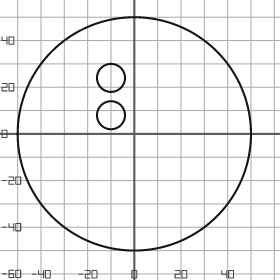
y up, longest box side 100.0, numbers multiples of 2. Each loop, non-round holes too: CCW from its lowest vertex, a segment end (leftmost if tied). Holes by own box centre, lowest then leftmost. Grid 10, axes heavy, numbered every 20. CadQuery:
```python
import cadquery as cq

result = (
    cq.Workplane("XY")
    .moveTo(0.0, 0.0)
    .circle(50.0)
    .moveTo(-10.0, 8.0)
    .circle(6.0)
    .moveTo(-10.0, 24.0)
    .circle(6.0)
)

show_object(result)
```